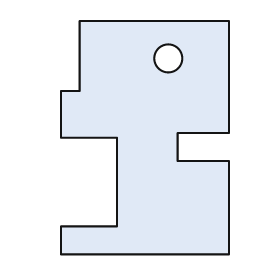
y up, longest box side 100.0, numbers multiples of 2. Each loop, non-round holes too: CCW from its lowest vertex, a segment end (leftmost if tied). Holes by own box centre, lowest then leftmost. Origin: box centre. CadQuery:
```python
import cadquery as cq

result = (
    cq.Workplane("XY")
    .moveTo(-36.0, -50.0)
    .lineTo(36.0, -50.0)
    .lineTo(36.0, -10.0)
    .lineTo(14.0, -10.0)
    .lineTo(14.0, 2.0)
    .lineTo(36.0, 2.0)
    .lineTo(36.0, 50.0)
    .lineTo(-28.0, 50.0)
    .lineTo(-28.0, 20.0)
    .lineTo(-36.0, 20.0)
    .lineTo(-36.0, 0.0)
    .lineTo(-12.0, 0.0)
    .lineTo(-12.0, -38.0)
    .lineTo(-36.0, -38.0)
    .close()
    .moveTo(10.0, 34.0)
    .circle(6.0)
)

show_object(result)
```